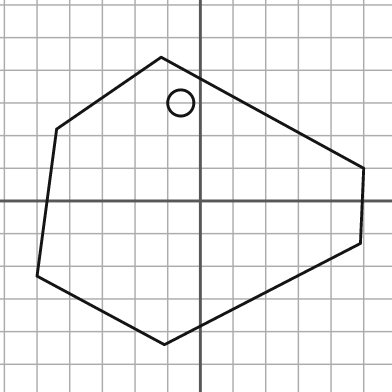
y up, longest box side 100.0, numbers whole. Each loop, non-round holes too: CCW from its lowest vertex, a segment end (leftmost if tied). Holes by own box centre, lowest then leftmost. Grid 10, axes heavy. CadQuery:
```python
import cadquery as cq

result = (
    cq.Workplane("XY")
    .moveTo(-11.0, -44.0)
    .lineTo(49.0, -13.0)
    .lineTo(50.0, 10.0)
    .lineTo(-12.0, 44.0)
    .lineTo(-44.0, 22.0)
    .lineTo(-50.0, -23.0)
    .close()
    .moveTo(-6.0, 30.0)
    .circle(4.0)
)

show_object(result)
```